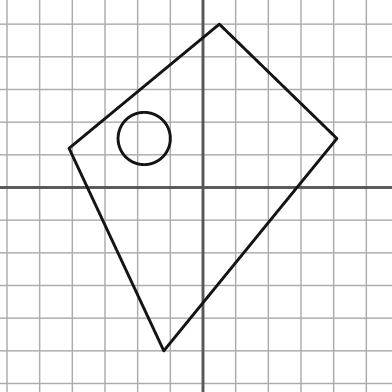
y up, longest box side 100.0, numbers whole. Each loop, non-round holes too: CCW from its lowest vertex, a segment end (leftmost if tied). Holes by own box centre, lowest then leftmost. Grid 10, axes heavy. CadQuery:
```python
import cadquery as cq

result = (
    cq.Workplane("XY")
    .moveTo(-12.0, -50.0)
    .lineTo(41.0, 15.0)
    .lineTo(5.0, 50.0)
    .lineTo(-41.0, 12.0)
    .close()
    .moveTo(-18.0, 15.0)
    .circle(8.0)
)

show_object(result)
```